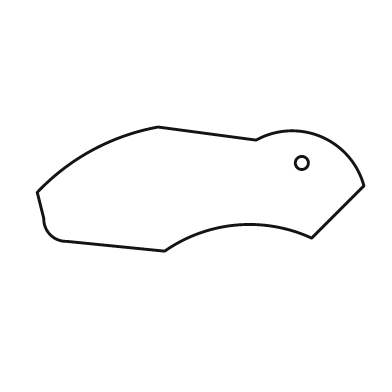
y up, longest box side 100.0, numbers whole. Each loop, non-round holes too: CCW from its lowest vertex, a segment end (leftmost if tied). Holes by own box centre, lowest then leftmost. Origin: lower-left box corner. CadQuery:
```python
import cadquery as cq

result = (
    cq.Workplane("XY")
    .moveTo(39.0, 0.0)
    .threePointArc((61.0, 8.0), (84.0, 4.0))
    .lineTo(100.0, 20.0)
    .threePointArc((87.0, 35.0), (67.0, 34.0))
    .lineTo(37.0, 38.0)
    .threePointArc((17.0, 31.0), (0.0, 18.0))
    .lineTo(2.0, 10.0)
    .threePointArc((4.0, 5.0), (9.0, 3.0))
    .close()
    .moveTo(81.0, 27.0)
    .circle(2.0)
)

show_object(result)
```